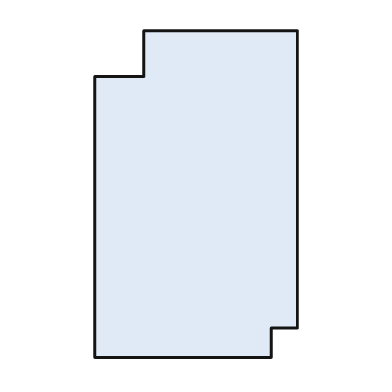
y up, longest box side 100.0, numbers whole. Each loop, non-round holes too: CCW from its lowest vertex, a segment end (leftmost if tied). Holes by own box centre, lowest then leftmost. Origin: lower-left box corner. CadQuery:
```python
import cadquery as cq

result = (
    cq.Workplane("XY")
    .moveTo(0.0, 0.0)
    .lineTo(54.0, 0.0)
    .lineTo(54.0, 9.0)
    .lineTo(62.0, 9.0)
    .lineTo(62.0, 100.0)
    .lineTo(15.0, 100.0)
    .lineTo(15.0, 86.0)
    .lineTo(0.0, 86.0)
    .close()
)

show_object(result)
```